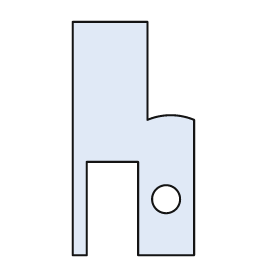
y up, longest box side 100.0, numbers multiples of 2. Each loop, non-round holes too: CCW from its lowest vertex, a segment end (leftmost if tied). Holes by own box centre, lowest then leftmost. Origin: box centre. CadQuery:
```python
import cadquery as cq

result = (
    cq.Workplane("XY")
    .moveTo(-26.0, -50.0)
    .lineTo(-20.0, -50.0)
    .lineTo(-20.0, -10.0)
    .lineTo(2.0, -10.0)
    .lineTo(2.0, -50.0)
    .lineTo(26.0, -50.0)
    .lineTo(26.0, 8.0)
    .threePointArc((16.0, 10.0), (6.0, 8.0))
    .lineTo(6.0, 50.0)
    .lineTo(-26.0, 50.0)
    .close()
    .moveTo(14.0, -26.0)
    .circle(6.0)
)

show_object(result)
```